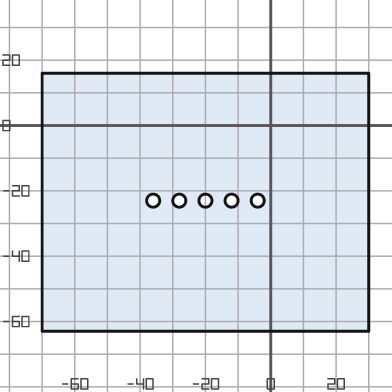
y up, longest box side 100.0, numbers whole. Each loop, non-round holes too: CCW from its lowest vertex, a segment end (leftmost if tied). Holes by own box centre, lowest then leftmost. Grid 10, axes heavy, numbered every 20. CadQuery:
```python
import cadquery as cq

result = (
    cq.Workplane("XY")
    .moveTo(-70.0, -63.0)
    .lineTo(30.0, -63.0)
    .lineTo(30.0, 16.0)
    .lineTo(-70.0, 16.0)
    .close()
    .moveTo(-36.0, -23.0)
    .circle(2.0)
    .moveTo(-28.0, -23.0)
    .circle(2.0)
    .moveTo(-20.0, -23.0)
    .circle(2.0)
    .moveTo(-12.0, -23.0)
    .circle(2.0)
    .moveTo(-4.0, -23.0)
    .circle(2.0)
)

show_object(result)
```